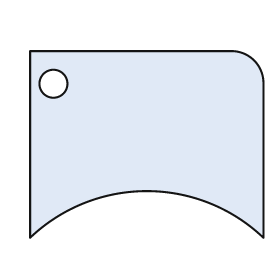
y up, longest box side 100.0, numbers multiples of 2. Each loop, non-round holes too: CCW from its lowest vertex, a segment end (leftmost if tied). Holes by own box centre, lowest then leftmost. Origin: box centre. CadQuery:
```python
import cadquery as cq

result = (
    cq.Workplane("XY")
    .moveTo(-50.0, -40.0)
    .threePointArc((0.0, -20.0), (50.0, -40.0))
    .lineTo(50.0, 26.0)
    .threePointArc((46.0, 36.0), (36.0, 40.0))
    .lineTo(-50.0, 40.0)
    .close()
    .moveTo(-40.0, 26.0)
    .circle(6.0)
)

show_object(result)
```